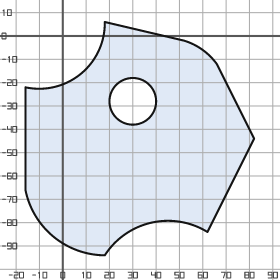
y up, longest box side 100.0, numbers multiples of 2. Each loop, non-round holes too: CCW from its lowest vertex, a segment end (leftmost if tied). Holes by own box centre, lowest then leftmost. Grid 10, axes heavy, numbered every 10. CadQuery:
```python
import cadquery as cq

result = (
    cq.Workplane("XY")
    .moveTo(18.0, -94.0)
    .threePointArc((38.0, -80.0), (62.0, -84.0))
    .lineTo(82.0, -44.0)
    .lineTo(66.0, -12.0)
    .threePointArc((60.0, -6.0), (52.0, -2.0))
    .lineTo(18.0, 6.0)
    .threePointArc((8.0, -16.0), (-16.0, -22.0))
    .lineTo(-16.0, -66.0)
    .threePointArc((-4.0, -86.0), (18.0, -94.0))
    .close()
    .moveTo(30.0, -28.0)
    .circle(10.0)
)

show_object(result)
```